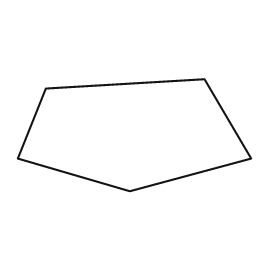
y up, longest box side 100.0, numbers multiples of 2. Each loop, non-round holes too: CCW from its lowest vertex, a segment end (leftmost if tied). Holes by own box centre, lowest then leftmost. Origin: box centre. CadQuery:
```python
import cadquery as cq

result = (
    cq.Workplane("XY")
    .moveTo(-2.0, -24.0)
    .lineTo(50.0, -10.0)
    .lineTo(30.0, 24.0)
    .lineTo(-38.0, 20.0)
    .lineTo(-50.0, -10.0)
    .close()
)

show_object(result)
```